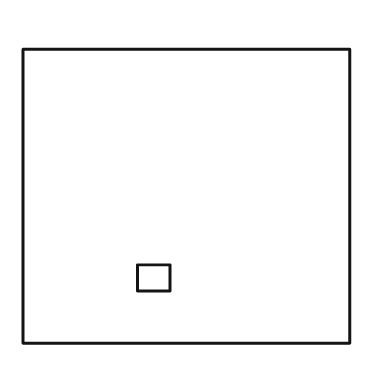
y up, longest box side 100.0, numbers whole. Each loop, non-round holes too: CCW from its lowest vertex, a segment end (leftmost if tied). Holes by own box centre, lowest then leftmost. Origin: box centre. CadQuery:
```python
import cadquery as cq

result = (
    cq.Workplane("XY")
    .moveTo(-50.0, -45.0)
    .lineTo(50.0, -45.0)
    .lineTo(50.0, 45.0)
    .lineTo(-50.0, 45.0)
    .close()
    .moveTo(-15.0, -29.0)
    .lineTo(-5.0, -29.0)
    .lineTo(-5.0, -21.0)
    .lineTo(-15.0, -21.0)
    .close()
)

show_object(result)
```